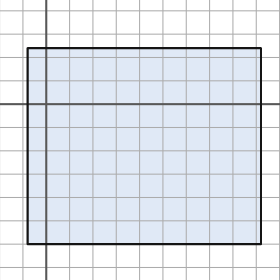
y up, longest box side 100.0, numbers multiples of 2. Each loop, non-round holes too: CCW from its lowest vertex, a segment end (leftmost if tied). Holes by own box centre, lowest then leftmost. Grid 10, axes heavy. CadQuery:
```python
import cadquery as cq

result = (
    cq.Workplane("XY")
    .moveTo(-8.0, -60.0)
    .lineTo(92.0, -60.0)
    .lineTo(92.0, 24.0)
    .lineTo(-8.0, 24.0)
    .close()
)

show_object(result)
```